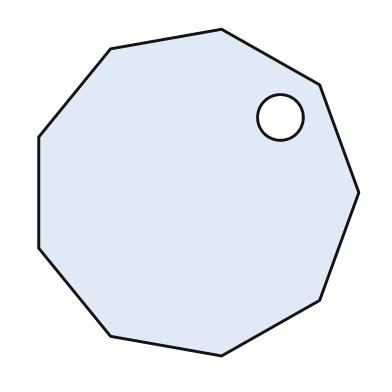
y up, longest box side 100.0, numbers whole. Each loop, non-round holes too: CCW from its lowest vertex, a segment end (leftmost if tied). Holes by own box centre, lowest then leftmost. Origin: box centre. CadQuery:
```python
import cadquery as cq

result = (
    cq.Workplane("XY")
    .moveTo(7.0, -50.0)
    .lineTo(37.0, -33.0)
    .lineTo(49.0, 0.0)
    .lineTo(37.0, 33.0)
    .lineTo(7.0, 50.0)
    .lineTo(-27.0, 44.0)
    .lineTo(-49.0, 17.0)
    .lineTo(-49.0, -17.0)
    .lineTo(-27.0, -44.0)
    .close()
    .moveTo(25.0, 23.0)
    .circle(7.0)
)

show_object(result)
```